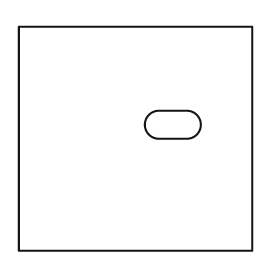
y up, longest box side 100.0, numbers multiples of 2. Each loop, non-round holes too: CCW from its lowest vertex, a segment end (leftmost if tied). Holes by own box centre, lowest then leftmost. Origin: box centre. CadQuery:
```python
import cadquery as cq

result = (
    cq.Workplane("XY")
    .moveTo(-50.0, -48.0)
    .lineTo(50.0, -48.0)
    .lineTo(50.0, 48.0)
    .lineTo(-50.0, 48.0)
    .close()
    .moveTo(10.0, 0.0)
    .lineTo(22.0, 0.0)
    .threePointArc((28.0, 6.0), (22.0, 12.0))
    .lineTo(10.0, 12.0)
    .threePointArc((4.0, 6.0), (10.0, 0.0))
    .close()
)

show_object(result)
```